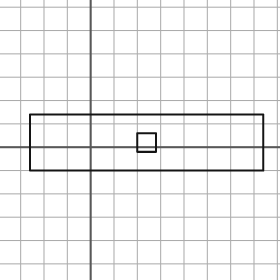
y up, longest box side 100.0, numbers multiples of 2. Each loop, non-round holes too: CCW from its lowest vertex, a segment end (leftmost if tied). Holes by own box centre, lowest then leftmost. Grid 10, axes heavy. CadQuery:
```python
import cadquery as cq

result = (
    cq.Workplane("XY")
    .moveTo(-26.0, -10.0)
    .lineTo(74.0, -10.0)
    .lineTo(74.0, 14.0)
    .lineTo(-26.0, 14.0)
    .close()
    .moveTo(20.0, -2.0)
    .lineTo(28.0, -2.0)
    .lineTo(28.0, 6.0)
    .lineTo(20.0, 6.0)
    .close()
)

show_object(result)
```